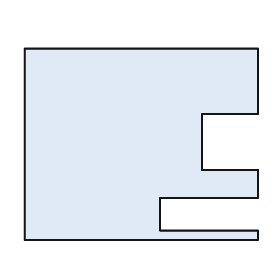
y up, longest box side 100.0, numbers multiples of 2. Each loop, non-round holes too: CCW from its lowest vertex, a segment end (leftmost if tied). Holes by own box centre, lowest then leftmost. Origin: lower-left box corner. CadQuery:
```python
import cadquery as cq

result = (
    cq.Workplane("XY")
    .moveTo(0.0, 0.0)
    .lineTo(100.0, 0.0)
    .lineTo(100.0, 4.0)
    .lineTo(58.0, 4.0)
    .lineTo(58.0, 18.0)
    .lineTo(100.0, 18.0)
    .lineTo(100.0, 30.0)
    .lineTo(76.0, 30.0)
    .lineTo(76.0, 54.0)
    .lineTo(100.0, 54.0)
    .lineTo(100.0, 82.0)
    .lineTo(0.0, 82.0)
    .close()
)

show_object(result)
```